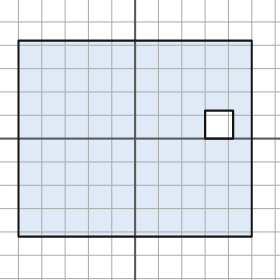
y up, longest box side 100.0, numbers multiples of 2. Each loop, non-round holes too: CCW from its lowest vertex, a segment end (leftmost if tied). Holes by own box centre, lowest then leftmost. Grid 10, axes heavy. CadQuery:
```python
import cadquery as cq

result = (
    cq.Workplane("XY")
    .moveTo(-50.0, -42.0)
    .lineTo(50.0, -42.0)
    .lineTo(50.0, 42.0)
    .lineTo(-50.0, 42.0)
    .close()
    .moveTo(30.0, 0.0)
    .lineTo(42.0, 0.0)
    .lineTo(42.0, 12.0)
    .lineTo(30.0, 12.0)
    .close()
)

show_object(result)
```